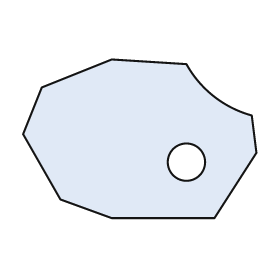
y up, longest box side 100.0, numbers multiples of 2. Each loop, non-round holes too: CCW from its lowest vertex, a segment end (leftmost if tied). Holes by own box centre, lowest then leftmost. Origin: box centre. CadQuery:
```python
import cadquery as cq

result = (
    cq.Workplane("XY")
    .moveTo(-12.0, -34.0)
    .lineTo(32.0, -34.0)
    .lineTo(50.0, -6.0)
    .lineTo(48.0, 10.0)
    .threePointArc((32.0, 18.0), (20.0, 32.0))
    .lineTo(-12.0, 34.0)
    .lineTo(-42.0, 22.0)
    .lineTo(-50.0, 2.0)
    .lineTo(-34.0, -26.0)
    .close()
    .moveTo(20.0, -10.0)
    .circle(8.0)
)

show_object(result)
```